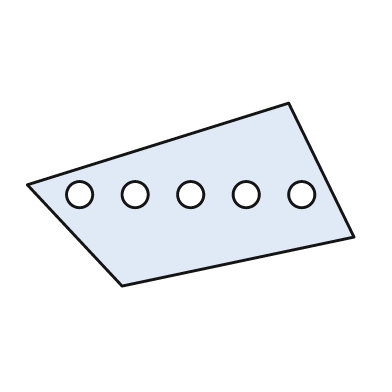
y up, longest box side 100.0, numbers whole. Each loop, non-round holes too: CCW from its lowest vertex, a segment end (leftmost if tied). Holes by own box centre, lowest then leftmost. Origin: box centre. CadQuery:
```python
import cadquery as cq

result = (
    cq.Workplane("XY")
    .moveTo(-21.0, -28.0)
    .lineTo(50.0, -13.0)
    .lineTo(30.0, 28.0)
    .lineTo(-50.0, 3.0)
    .close()
    .moveTo(-34.0, 0.0)
    .circle(4.0)
    .moveTo(-17.0, 0.0)
    .circle(4.0)
    .moveTo(0.0, 0.0)
    .circle(4.0)
    .moveTo(17.0, 0.0)
    .circle(4.0)
    .moveTo(34.0, 0.0)
    .circle(4.0)
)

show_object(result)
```